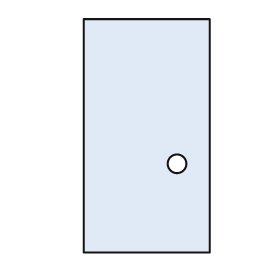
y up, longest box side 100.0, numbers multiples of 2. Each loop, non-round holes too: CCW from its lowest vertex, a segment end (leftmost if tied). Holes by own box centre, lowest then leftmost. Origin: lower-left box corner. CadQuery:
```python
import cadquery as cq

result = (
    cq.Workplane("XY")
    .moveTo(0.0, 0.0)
    .lineTo(54.0, 0.0)
    .lineTo(54.0, 100.0)
    .lineTo(0.0, 100.0)
    .close()
    .moveTo(40.0, 38.0)
    .circle(4.0)
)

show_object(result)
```